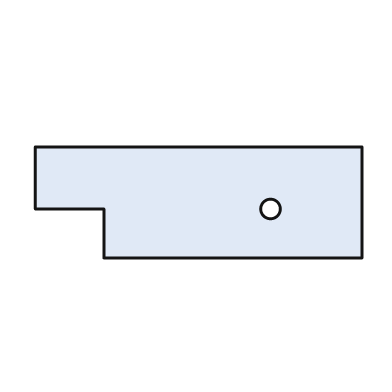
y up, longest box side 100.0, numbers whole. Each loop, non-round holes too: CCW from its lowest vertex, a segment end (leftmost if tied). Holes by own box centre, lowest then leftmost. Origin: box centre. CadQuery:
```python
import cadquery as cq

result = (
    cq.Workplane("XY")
    .moveTo(-29.0, -17.0)
    .lineTo(50.0, -17.0)
    .lineTo(50.0, 17.0)
    .lineTo(-50.0, 17.0)
    .lineTo(-50.0, -2.0)
    .lineTo(-29.0, -2.0)
    .close()
    .moveTo(22.0, -2.0)
    .circle(3.0)
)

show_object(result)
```